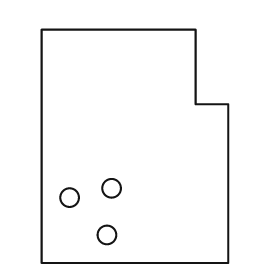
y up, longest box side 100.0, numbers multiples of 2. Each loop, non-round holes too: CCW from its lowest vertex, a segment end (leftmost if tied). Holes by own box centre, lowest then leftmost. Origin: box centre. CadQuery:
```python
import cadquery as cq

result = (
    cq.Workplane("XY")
    .moveTo(-40.0, -50.0)
    .lineTo(40.0, -50.0)
    .lineTo(40.0, 18.0)
    .lineTo(26.0, 18.0)
    .lineTo(26.0, 50.0)
    .lineTo(-40.0, 50.0)
    .close()
    .moveTo(-12.0, -38.0)
    .circle(4.0)
    .moveTo(-28.0, -22.0)
    .circle(4.0)
    .moveTo(-10.0, -18.0)
    .circle(4.0)
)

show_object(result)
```